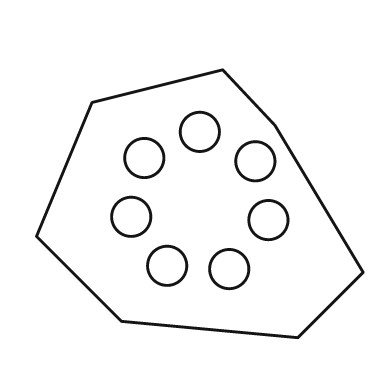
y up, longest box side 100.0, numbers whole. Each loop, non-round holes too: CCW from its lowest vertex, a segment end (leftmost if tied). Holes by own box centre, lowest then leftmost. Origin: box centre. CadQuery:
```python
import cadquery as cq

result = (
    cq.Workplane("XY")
    .moveTo(30.0, -41.0)
    .lineTo(50.0, -21.0)
    .lineTo(23.0, 24.0)
    .lineTo(7.0, 41.0)
    .lineTo(-33.0, 31.0)
    .lineTo(-50.0, -10.0)
    .lineTo(-24.0, -36.0)
    .close()
    .moveTo(9.0, -20.0)
    .circle(6.0)
    .moveTo(-10.0, -19.0)
    .circle(6.0)
    .moveTo(21.0, -5.0)
    .circle(6.0)
    .moveTo(-21.0, -4.0)
    .circle(6.0)
    .moveTo(17.0, 13.0)
    .circle(6.0)
    .moveTo(-17.0, 14.0)
    .circle(6.0)
    .moveTo(0.0, 22.0)
    .circle(6.0)
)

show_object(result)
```